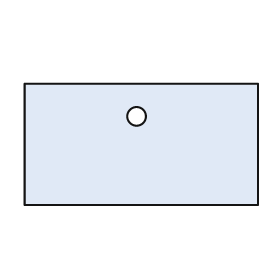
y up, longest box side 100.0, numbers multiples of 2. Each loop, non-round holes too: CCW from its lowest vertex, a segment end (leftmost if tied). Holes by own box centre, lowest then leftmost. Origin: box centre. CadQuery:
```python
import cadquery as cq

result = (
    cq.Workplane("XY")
    .moveTo(-50.0, -26.0)
    .lineTo(50.0, -26.0)
    .lineTo(50.0, 26.0)
    .lineTo(-50.0, 26.0)
    .close()
    .moveTo(-2.0, 12.0)
    .circle(4.0)
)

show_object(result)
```